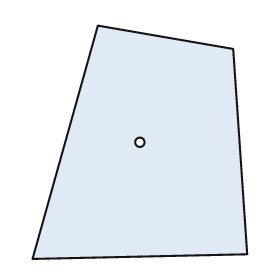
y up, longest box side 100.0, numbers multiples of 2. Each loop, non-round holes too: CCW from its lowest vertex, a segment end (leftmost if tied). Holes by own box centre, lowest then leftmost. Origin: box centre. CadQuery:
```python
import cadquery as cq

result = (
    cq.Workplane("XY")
    .moveTo(-46.0, -50.0)
    .lineTo(46.0, -48.0)
    .lineTo(40.0, 40.0)
    .lineTo(-18.0, 50.0)
    .close()
    .moveTo(0.0, 0.0)
    .circle(2.0)
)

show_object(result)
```